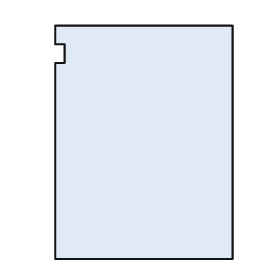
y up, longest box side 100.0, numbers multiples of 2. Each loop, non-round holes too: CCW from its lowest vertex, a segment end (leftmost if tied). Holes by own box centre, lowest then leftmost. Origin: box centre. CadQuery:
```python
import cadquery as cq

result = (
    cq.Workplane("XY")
    .moveTo(-38.0, -50.0)
    .lineTo(38.0, -50.0)
    .lineTo(38.0, 50.0)
    .lineTo(-38.0, 50.0)
    .lineTo(-38.0, 42.0)
    .lineTo(-34.0, 42.0)
    .lineTo(-34.0, 34.0)
    .lineTo(-38.0, 34.0)
    .close()
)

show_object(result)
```